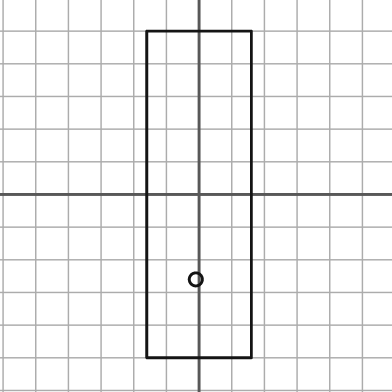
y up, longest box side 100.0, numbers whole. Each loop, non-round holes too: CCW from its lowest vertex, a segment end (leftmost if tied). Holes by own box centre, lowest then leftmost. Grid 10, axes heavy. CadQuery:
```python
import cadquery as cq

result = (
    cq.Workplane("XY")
    .moveTo(-16.0, -50.0)
    .lineTo(16.0, -50.0)
    .lineTo(16.0, 50.0)
    .lineTo(-16.0, 50.0)
    .close()
    .moveTo(-1.0, -26.0)
    .circle(2.0)
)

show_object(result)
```